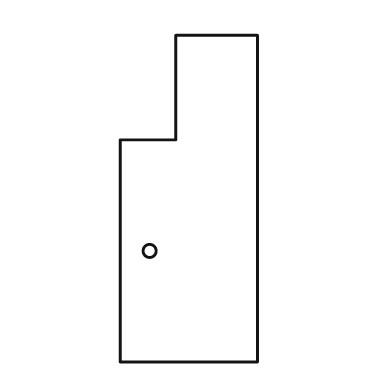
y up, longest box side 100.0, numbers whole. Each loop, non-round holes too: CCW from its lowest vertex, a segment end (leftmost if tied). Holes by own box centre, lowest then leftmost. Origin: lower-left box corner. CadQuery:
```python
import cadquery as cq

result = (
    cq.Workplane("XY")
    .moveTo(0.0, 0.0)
    .lineTo(42.0, 0.0)
    .lineTo(42.0, 100.0)
    .lineTo(17.0, 100.0)
    .lineTo(17.0, 68.0)
    .lineTo(0.0, 68.0)
    .close()
    .moveTo(9.0, 34.0)
    .circle(2.0)
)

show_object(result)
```